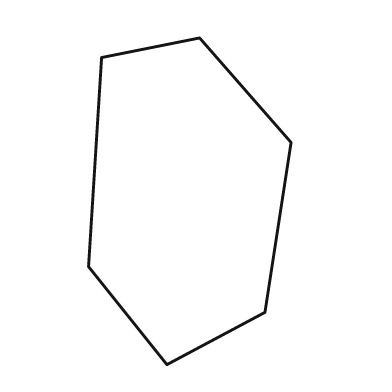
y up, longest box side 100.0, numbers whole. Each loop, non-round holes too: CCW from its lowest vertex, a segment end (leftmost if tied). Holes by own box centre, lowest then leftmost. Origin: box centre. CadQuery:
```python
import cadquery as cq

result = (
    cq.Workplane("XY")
    .moveTo(-7.0, -50.0)
    .lineTo(23.0, -34.0)
    .lineTo(31.0, 18.0)
    .lineTo(3.0, 50.0)
    .lineTo(-27.0, 44.0)
    .lineTo(-31.0, -20.0)
    .close()
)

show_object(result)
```